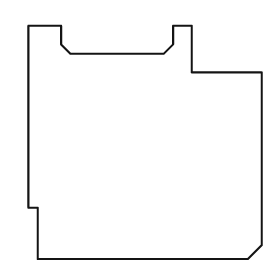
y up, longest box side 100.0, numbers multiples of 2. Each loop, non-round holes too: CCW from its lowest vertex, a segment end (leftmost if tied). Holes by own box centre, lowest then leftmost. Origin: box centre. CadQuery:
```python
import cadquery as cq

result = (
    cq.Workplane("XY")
    .moveTo(-46.0, -50.0)
    .lineTo(44.0, -50.0)
    .lineTo(50.0, -44.0)
    .lineTo(50.0, 30.0)
    .lineTo(20.0, 30.0)
    .lineTo(20.0, 50.0)
    .lineTo(12.0, 50.0)
    .lineTo(12.0, 42.0)
    .lineTo(8.0, 38.0)
    .lineTo(-32.0, 38.0)
    .lineTo(-36.0, 42.0)
    .lineTo(-36.0, 50.0)
    .lineTo(-50.0, 50.0)
    .lineTo(-50.0, -28.0)
    .lineTo(-46.0, -28.0)
    .close()
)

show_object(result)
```